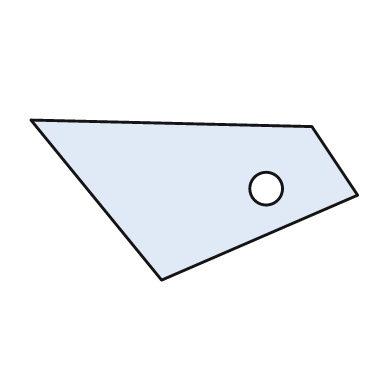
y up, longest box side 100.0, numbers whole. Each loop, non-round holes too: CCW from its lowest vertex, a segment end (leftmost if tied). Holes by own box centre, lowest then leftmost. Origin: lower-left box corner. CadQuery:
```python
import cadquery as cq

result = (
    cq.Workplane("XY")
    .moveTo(40.0, 0.0)
    .lineTo(100.0, 26.0)
    .lineTo(86.0, 47.0)
    .lineTo(0.0, 49.0)
    .close()
    .moveTo(72.0, 28.0)
    .circle(5.0)
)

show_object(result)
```